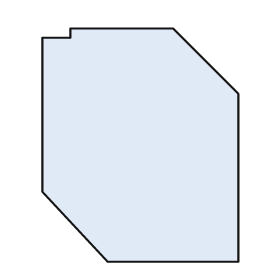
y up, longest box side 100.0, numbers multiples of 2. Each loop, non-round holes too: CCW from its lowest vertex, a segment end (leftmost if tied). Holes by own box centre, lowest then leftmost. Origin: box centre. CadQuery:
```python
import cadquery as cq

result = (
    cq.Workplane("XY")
    .moveTo(-14.0, -50.0)
    .lineTo(42.0, -50.0)
    .lineTo(42.0, 22.0)
    .lineTo(14.0, 50.0)
    .lineTo(-30.0, 50.0)
    .lineTo(-30.0, 46.0)
    .lineTo(-42.0, 46.0)
    .lineTo(-42.0, -20.0)
    .close()
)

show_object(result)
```